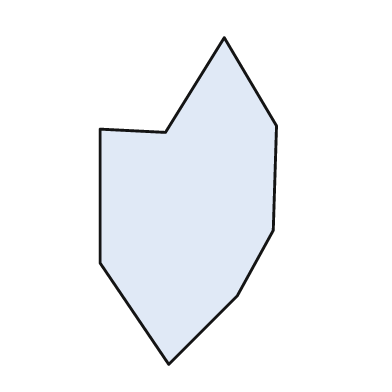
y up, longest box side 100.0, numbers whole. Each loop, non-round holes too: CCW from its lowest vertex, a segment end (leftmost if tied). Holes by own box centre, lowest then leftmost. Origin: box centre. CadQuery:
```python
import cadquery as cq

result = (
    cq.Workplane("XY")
    .moveTo(-6.0, -50.0)
    .lineTo(15.0, -29.0)
    .lineTo(26.0, -9.0)
    .lineTo(27.0, 23.0)
    .lineTo(11.0, 50.0)
    .lineTo(-7.0, 21.0)
    .lineTo(-27.0, 22.0)
    .lineTo(-27.0, -19.0)
    .close()
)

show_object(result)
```